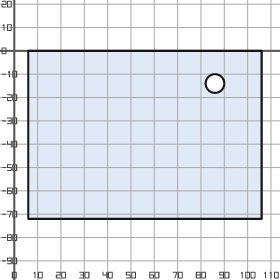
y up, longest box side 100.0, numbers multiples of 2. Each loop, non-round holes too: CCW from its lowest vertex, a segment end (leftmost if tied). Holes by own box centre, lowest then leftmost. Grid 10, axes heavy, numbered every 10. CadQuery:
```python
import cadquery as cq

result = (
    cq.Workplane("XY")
    .moveTo(6.0, -72.0)
    .lineTo(106.0, -72.0)
    .lineTo(106.0, 0.0)
    .lineTo(6.0, 0.0)
    .close()
    .moveTo(86.0, -14.0)
    .circle(4.0)
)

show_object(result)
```